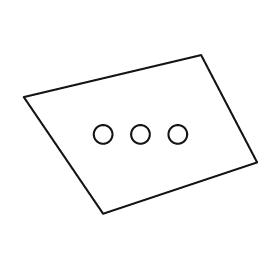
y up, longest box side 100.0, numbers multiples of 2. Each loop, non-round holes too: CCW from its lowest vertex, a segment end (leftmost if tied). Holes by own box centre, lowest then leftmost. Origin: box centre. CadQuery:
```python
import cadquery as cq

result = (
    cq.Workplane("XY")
    .moveTo(-16.0, -34.0)
    .lineTo(50.0, -12.0)
    .lineTo(26.0, 34.0)
    .lineTo(-50.0, 16.0)
    .close()
    .moveTo(-16.0, 0.0)
    .circle(4.0)
    .moveTo(0.0, 0.0)
    .circle(4.0)
    .moveTo(16.0, 0.0)
    .circle(4.0)
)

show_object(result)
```